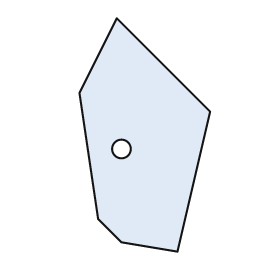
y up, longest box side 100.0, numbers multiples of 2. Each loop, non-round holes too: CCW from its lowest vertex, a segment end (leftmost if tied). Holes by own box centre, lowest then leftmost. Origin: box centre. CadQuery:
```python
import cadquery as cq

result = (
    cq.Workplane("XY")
    .moveTo(14.0, -50.0)
    .lineTo(28.0, 10.0)
    .lineTo(-12.0, 50.0)
    .lineTo(-28.0, 18.0)
    .lineTo(-20.0, -36.0)
    .lineTo(-10.0, -46.0)
    .close()
    .moveTo(-10.0, -6.0)
    .circle(4.0)
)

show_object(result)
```